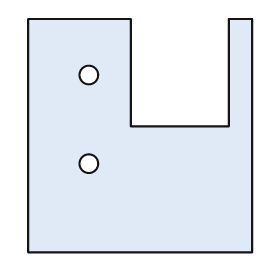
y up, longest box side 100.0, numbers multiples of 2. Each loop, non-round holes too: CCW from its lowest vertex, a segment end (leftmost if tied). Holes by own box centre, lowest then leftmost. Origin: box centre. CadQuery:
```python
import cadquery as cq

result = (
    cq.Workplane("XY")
    .moveTo(-48.0, -50.0)
    .lineTo(48.0, -50.0)
    .lineTo(48.0, 50.0)
    .lineTo(38.0, 50.0)
    .lineTo(38.0, 4.0)
    .lineTo(-4.0, 4.0)
    .lineTo(-4.0, 50.0)
    .lineTo(-48.0, 50.0)
    .close()
    .moveTo(-22.0, -12.0)
    .circle(4.0)
    .moveTo(-22.0, 26.0)
    .circle(4.0)
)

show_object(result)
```